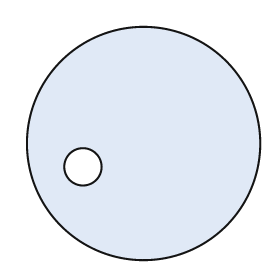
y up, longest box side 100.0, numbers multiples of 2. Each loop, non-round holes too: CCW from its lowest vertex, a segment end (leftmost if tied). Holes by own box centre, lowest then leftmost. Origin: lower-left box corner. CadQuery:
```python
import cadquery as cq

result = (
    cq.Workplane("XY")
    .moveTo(50.0, 50.0)
    .circle(50.0)
    .moveTo(24.0, 40.0)
    .circle(8.0)
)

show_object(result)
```